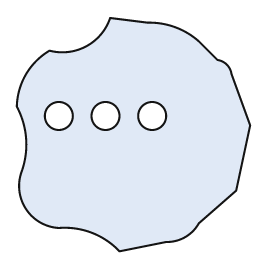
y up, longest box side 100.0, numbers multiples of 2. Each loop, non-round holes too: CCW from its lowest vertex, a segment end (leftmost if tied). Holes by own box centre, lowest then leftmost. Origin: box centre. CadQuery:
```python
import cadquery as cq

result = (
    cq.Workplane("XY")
    .moveTo(-6.0, -50.0)
    .lineTo(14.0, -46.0)
    .threePointArc((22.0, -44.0), (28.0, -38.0))
    .lineTo(44.0, -24.0)
    .lineTo(50.0, 4.0)
    .lineTo(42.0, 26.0)
    .threePointArc((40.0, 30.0), (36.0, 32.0))
    .lineTo(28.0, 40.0)
    .threePointArc((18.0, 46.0), (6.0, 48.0))
    .lineTo(-10.0, 50.0)
    .threePointArc((-20.0, 38.0), (-36.0, 36.0))
    .threePointArc((-46.0, 26.0), (-50.0, 12.0))
    .threePointArc((-46.0, -2.0), (-48.0, -16.0))
    .threePointArc((-46.0, -32.0), (-32.0, -40.0))
    .threePointArc((-18.0, -42.0), (-6.0, -50.0))
    .close()
    .moveTo(-32.0, 8.0)
    .circle(6.0)
    .moveTo(-12.0, 8.0)
    .circle(6.0)
    .moveTo(8.0, 8.0)
    .circle(6.0)
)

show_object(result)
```